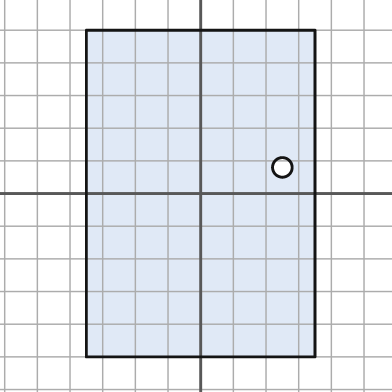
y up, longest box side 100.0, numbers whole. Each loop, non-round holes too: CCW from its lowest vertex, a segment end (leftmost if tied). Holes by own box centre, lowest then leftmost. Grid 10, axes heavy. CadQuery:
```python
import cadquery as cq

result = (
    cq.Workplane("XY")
    .moveTo(-35.0, -50.0)
    .lineTo(35.0, -50.0)
    .lineTo(35.0, 50.0)
    .lineTo(-35.0, 50.0)
    .close()
    .moveTo(25.0, 8.0)
    .circle(3.0)
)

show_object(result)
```